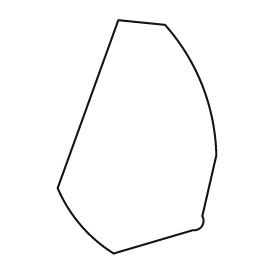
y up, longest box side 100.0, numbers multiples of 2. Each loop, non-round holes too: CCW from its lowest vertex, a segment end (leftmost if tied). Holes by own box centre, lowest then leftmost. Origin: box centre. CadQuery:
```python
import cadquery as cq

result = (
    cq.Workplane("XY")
    .moveTo(-10.0, -50.0)
    .lineTo(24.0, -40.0)
    .threePointArc((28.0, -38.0), (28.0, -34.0))
    .lineTo(34.0, -8.0)
    .threePointArc((28.0, 22.0), (12.0, 48.0))
    .lineTo(-8.0, 50.0)
    .lineTo(-34.0, -22.0)
    .threePointArc((-24.0, -38.0), (-10.0, -50.0))
    .close()
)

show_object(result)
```